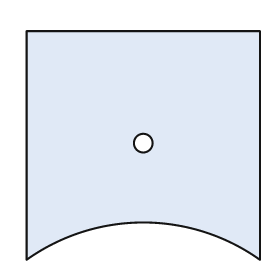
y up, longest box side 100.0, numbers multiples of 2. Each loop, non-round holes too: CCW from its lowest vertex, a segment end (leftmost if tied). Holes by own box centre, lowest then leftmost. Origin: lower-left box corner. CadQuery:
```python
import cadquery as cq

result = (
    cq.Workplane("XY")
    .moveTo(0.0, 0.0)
    .threePointArc((50.0, 16.0), (100.0, 0.0))
    .lineTo(100.0, 98.0)
    .lineTo(0.0, 98.0)
    .close()
    .moveTo(50.0, 50.0)
    .circle(4.0)
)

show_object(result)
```